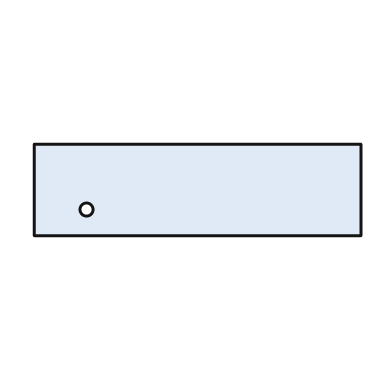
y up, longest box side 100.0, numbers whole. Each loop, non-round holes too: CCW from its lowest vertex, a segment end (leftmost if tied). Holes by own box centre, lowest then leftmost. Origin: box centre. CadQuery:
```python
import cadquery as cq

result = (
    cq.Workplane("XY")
    .moveTo(-50.0, -14.0)
    .lineTo(50.0, -14.0)
    .lineTo(50.0, 14.0)
    .lineTo(-50.0, 14.0)
    .close()
    .moveTo(-34.0, -6.0)
    .circle(2.0)
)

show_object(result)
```